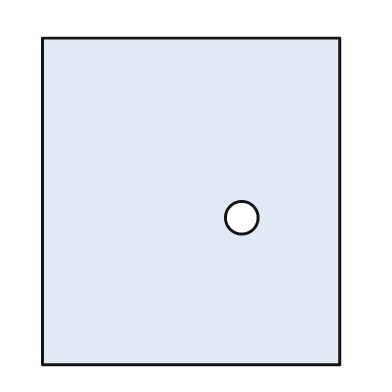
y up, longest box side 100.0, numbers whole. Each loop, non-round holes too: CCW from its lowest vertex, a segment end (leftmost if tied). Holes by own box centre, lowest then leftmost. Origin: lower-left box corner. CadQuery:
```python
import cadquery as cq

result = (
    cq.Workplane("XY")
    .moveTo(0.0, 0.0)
    .lineTo(91.0, 0.0)
    .lineTo(91.0, 100.0)
    .lineTo(0.0, 100.0)
    .close()
    .moveTo(61.0, 45.0)
    .circle(5.0)
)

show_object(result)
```